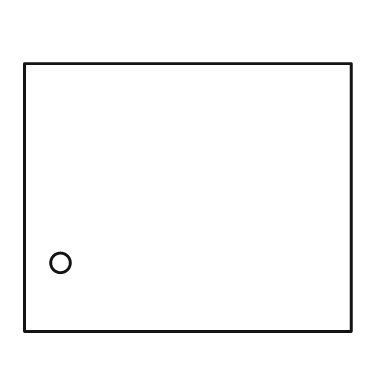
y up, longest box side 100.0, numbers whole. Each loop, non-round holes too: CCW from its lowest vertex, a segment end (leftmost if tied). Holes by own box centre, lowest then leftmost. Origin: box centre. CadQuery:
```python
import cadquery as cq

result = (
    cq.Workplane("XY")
    .moveTo(-50.0, -41.0)
    .lineTo(50.0, -41.0)
    .lineTo(50.0, 41.0)
    .lineTo(-50.0, 41.0)
    .close()
    .moveTo(-39.0, -20.0)
    .circle(3.0)
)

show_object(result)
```